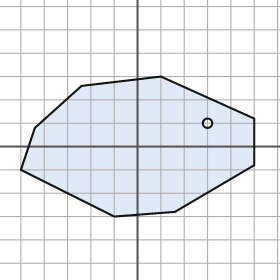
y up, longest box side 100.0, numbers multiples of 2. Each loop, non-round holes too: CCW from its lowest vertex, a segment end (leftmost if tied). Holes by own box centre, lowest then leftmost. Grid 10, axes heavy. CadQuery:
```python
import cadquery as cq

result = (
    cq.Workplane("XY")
    .moveTo(-10.0, -30.0)
    .lineTo(16.0, -28.0)
    .lineTo(50.0, -8.0)
    .lineTo(50.0, 12.0)
    .lineTo(10.0, 30.0)
    .lineTo(-24.0, 26.0)
    .lineTo(-44.0, 8.0)
    .lineTo(-50.0, -10.0)
    .close()
    .moveTo(30.0, 10.0)
    .circle(2.0)
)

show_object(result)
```